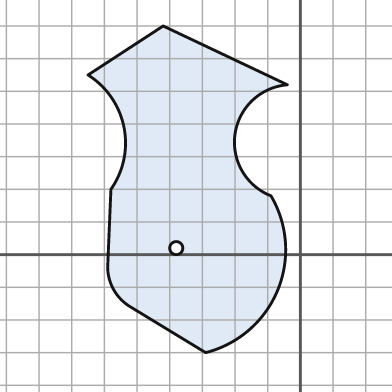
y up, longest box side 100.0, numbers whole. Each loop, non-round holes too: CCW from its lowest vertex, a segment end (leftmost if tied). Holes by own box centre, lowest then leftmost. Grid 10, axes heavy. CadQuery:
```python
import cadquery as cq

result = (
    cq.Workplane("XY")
    .moveTo(-29.0, -30.0)
    .threePointArc((-7.0, -11.0), (-9.0, 18.0))
    .threePointArc((-20.0, 37.0), (-4.0, 52.0))
    .lineTo(-42.0, 70.0)
    .lineTo(-65.0, 55.0)
    .threePointArc((-54.0, 39.0), (-58.0, 20.0))
    .lineTo(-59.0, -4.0)
    .threePointArc((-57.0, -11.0), (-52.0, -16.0))
    .close()
    .moveTo(-38.0, 2.0)
    .circle(2.0)
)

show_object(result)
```